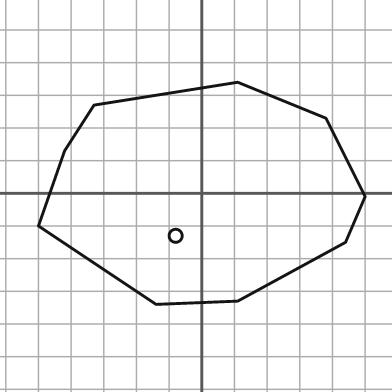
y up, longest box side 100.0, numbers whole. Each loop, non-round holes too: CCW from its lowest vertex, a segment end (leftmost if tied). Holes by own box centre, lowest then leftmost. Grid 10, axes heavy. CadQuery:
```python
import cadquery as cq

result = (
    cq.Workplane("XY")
    .moveTo(-14.0, -34.0)
    .lineTo(11.0, -33.0)
    .lineTo(44.0, -15.0)
    .lineTo(50.0, -1.0)
    .lineTo(38.0, 23.0)
    .lineTo(11.0, 34.0)
    .lineTo(-33.0, 27.0)
    .lineTo(-42.0, 13.0)
    .lineTo(-50.0, -10.0)
    .close()
    .moveTo(-8.0, -13.0)
    .circle(2.0)
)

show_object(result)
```